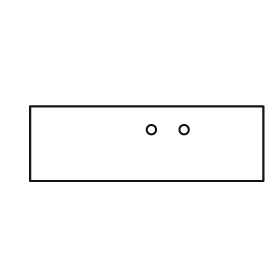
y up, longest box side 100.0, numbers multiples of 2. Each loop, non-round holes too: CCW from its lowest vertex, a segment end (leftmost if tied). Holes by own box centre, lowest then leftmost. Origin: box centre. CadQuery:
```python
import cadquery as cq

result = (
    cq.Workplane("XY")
    .moveTo(-50.0, -16.0)
    .lineTo(50.0, -16.0)
    .lineTo(50.0, 16.0)
    .lineTo(-50.0, 16.0)
    .close()
    .moveTo(2.0, 6.0)
    .circle(2.0)
    .moveTo(16.0, 6.0)
    .circle(2.0)
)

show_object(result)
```